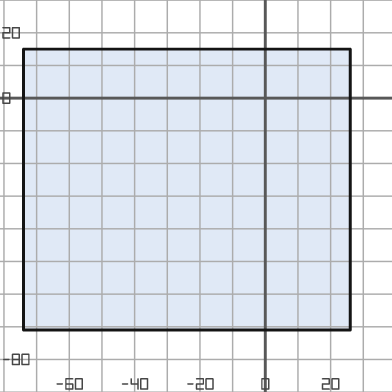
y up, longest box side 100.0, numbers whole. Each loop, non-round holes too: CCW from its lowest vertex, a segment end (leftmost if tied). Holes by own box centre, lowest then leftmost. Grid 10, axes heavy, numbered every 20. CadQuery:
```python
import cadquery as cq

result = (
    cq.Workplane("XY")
    .moveTo(-74.0, -71.0)
    .lineTo(26.0, -71.0)
    .lineTo(26.0, 15.0)
    .lineTo(-74.0, 15.0)
    .close()
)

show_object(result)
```